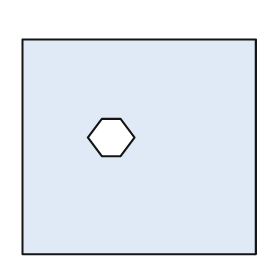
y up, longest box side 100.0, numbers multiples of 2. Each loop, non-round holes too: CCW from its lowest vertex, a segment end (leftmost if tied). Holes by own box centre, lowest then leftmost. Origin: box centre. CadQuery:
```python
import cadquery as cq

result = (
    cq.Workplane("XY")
    .moveTo(-50.0, -46.0)
    .lineTo(50.0, -46.0)
    .lineTo(50.0, 46.0)
    .lineTo(-50.0, 46.0)
    .close()
    .moveTo(-16.0, -4.0)
    .lineTo(-8.0, -4.0)
    .lineTo(-2.0, 4.0)
    .lineTo(-8.0, 12.0)
    .lineTo(-16.0, 12.0)
    .lineTo(-22.0, 4.0)
    .close()
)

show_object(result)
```